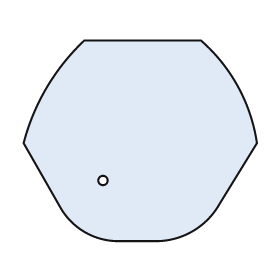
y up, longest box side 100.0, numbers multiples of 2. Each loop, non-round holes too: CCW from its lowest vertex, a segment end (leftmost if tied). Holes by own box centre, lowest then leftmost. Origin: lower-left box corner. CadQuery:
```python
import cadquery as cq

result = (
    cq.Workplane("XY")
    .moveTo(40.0, 0.0)
    .lineTo(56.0, 0.0)
    .threePointArc((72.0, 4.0), (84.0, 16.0))
    .lineTo(100.0, 42.0)
    .threePointArc((92.0, 66.0), (76.0, 86.0))
    .lineTo(26.0, 86.0)
    .threePointArc((10.0, 66.0), (0.0, 42.0))
    .lineTo(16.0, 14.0)
    .threePointArc((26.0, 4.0), (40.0, 0.0))
    .close()
    .moveTo(34.0, 26.0)
    .circle(2.0)
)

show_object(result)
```